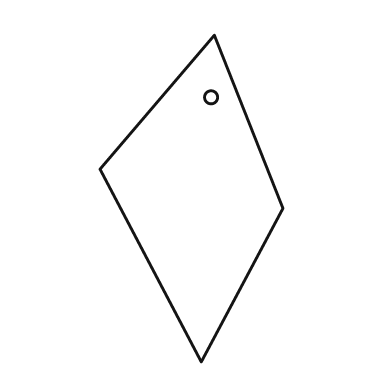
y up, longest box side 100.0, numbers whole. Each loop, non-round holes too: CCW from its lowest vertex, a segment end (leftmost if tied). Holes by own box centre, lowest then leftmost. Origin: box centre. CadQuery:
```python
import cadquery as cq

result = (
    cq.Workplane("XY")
    .moveTo(3.0, -50.0)
    .lineTo(28.0, -3.0)
    .lineTo(7.0, 50.0)
    .lineTo(-28.0, 9.0)
    .close()
    .moveTo(6.0, 31.0)
    .circle(2.0)
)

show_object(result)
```